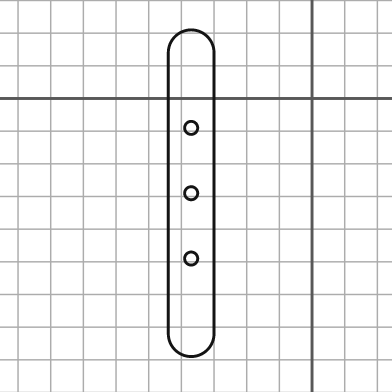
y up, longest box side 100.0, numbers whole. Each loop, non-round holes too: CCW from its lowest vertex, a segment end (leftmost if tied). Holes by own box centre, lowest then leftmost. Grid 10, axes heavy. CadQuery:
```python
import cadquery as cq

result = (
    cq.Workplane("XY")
    .moveTo(-44.0, -72.0)
    .threePointArc((-37.0, -79.0), (-30.0, -72.0))
    .lineTo(-30.0, 14.0)
    .threePointArc((-37.0, 21.0), (-44.0, 14.0))
    .close()
    .moveTo(-37.0, -49.0)
    .circle(2.0)
    .moveTo(-37.0, -29.0)
    .circle(2.0)
    .moveTo(-37.0, -9.0)
    .circle(2.0)
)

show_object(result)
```